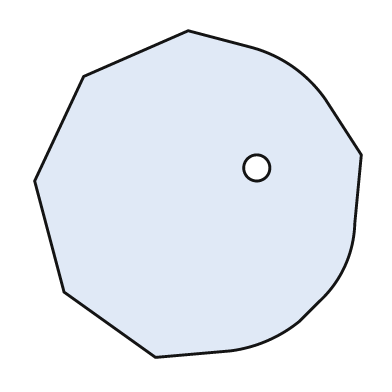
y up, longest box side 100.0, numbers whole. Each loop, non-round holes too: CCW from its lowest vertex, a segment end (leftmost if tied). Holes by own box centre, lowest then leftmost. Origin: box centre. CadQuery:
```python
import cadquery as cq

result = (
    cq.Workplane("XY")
    .moveTo(-13.0, -50.0)
    .lineTo(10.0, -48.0)
    .threePointArc((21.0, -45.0), (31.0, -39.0))
    .lineTo(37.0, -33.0)
    .threePointArc((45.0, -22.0), (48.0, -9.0))
    .lineTo(50.0, 12.0)
    .lineTo(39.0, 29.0)
    .threePointArc((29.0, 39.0), (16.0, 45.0))
    .lineTo(-3.0, 50.0)
    .lineTo(-35.0, 36.0)
    .lineTo(-50.0, 4.0)
    .lineTo(-41.0, -30.0)
    .close()
    .moveTo(18.0, 8.0)
    .circle(4.0)
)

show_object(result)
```